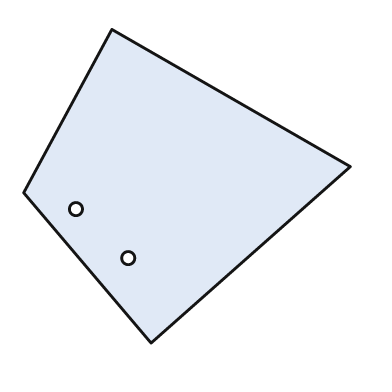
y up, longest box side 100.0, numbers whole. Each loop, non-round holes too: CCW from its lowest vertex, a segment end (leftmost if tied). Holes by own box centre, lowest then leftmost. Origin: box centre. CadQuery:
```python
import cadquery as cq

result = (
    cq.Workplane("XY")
    .moveTo(-11.0, -48.0)
    .lineTo(50.0, 6.0)
    .lineTo(-23.0, 48.0)
    .lineTo(-50.0, -2.0)
    .close()
    .moveTo(-18.0, -22.0)
    .circle(2.0)
    .moveTo(-34.0, -7.0)
    .circle(2.0)
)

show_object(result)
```